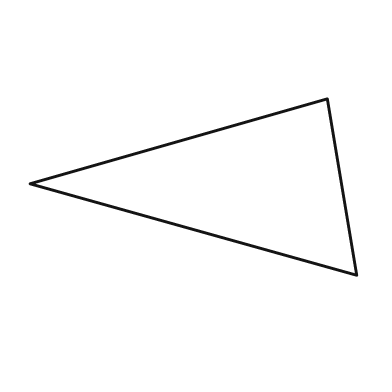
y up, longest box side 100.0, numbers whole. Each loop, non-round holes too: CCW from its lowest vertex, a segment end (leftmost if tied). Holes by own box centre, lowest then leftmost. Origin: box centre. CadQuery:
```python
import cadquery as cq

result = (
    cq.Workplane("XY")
    .moveTo(50.0, -27.0)
    .lineTo(41.0, 27.0)
    .lineTo(-50.0, 1.0)
    .close()
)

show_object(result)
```